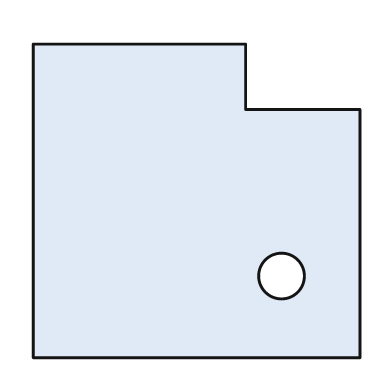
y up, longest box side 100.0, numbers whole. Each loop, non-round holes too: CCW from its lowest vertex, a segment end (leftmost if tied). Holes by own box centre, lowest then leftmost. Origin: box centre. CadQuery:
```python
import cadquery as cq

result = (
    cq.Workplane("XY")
    .moveTo(-50.0, -48.0)
    .lineTo(50.0, -48.0)
    .lineTo(50.0, 28.0)
    .lineTo(15.0, 28.0)
    .lineTo(15.0, 48.0)
    .lineTo(-50.0, 48.0)
    .close()
    .moveTo(26.0, -23.0)
    .circle(7.0)
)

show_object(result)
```